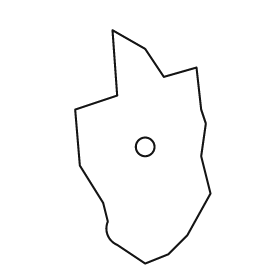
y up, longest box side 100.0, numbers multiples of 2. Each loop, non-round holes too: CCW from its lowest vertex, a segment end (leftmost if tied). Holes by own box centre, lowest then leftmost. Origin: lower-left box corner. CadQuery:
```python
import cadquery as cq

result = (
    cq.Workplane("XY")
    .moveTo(30.0, 0.0)
    .lineTo(40.0, 4.0)
    .lineTo(48.0, 12.0)
    .lineTo(58.0, 30.0)
    .lineTo(54.0, 46.0)
    .lineTo(56.0, 60.0)
    .lineTo(54.0, 66.0)
    .lineTo(52.0, 84.0)
    .lineTo(38.0, 80.0)
    .lineTo(30.0, 92.0)
    .lineTo(16.0, 100.0)
    .lineTo(18.0, 72.0)
    .lineTo(0.0, 66.0)
    .lineTo(2.0, 42.0)
    .lineTo(12.0, 26.0)
    .lineTo(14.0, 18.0)
    .threePointArc((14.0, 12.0), (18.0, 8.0))
    .close()
    .moveTo(30.0, 50.0)
    .circle(4.0)
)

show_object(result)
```